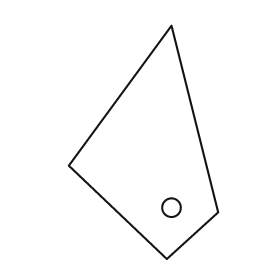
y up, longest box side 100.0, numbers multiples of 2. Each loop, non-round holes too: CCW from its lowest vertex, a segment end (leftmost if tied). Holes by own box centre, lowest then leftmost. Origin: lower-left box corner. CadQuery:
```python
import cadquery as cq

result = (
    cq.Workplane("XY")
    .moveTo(42.0, 0.0)
    .lineTo(64.0, 20.0)
    .lineTo(44.0, 100.0)
    .lineTo(0.0, 40.0)
    .close()
    .moveTo(44.0, 22.0)
    .circle(4.0)
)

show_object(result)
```